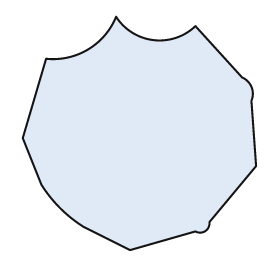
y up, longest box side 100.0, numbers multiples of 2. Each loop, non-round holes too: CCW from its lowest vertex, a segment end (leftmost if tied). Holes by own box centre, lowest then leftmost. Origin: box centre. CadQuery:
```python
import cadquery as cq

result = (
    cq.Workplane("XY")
    .moveTo(-4.0, -50.0)
    .lineTo(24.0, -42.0)
    .threePointArc((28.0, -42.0), (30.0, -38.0))
    .lineTo(50.0, -14.0)
    .lineTo(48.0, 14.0)
    .threePointArc((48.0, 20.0), (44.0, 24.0))
    .lineTo(24.0, 46.0)
    .threePointArc((6.0, 40.0), (-10.0, 50.0))
    .threePointArc((-22.0, 36.0), (-40.0, 32.0))
    .lineTo(-50.0, -2.0)
    .lineTo(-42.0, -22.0)
    .threePointArc((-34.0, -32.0), (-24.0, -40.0))
    .close()
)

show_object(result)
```